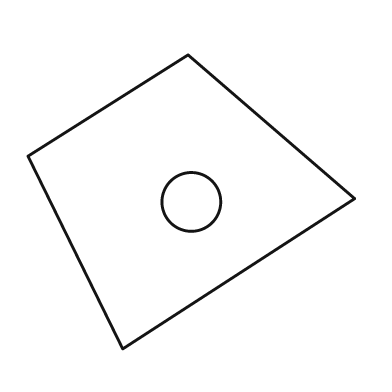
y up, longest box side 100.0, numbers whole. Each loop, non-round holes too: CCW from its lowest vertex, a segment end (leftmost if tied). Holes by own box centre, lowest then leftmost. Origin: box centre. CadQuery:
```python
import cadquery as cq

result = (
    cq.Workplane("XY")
    .moveTo(-21.0, -45.0)
    .lineTo(50.0, 1.0)
    .lineTo(-1.0, 45.0)
    .lineTo(-50.0, 14.0)
    .close()
    .moveTo(0.0, 0.0)
    .circle(9.0)
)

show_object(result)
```